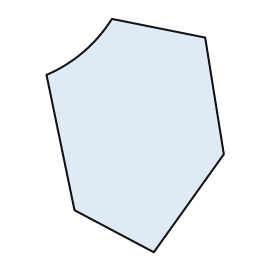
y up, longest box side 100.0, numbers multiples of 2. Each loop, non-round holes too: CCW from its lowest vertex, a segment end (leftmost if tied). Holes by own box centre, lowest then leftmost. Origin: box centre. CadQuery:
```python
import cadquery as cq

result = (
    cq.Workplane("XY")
    .moveTo(8.0, -50.0)
    .lineTo(38.0, -8.0)
    .lineTo(30.0, 42.0)
    .lineTo(-10.0, 50.0)
    .threePointArc((-22.0, 36.0), (-38.0, 26.0))
    .lineTo(-26.0, -32.0)
    .close()
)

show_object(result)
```